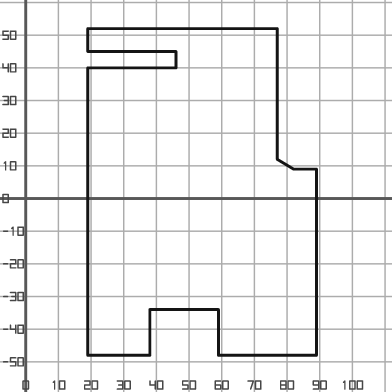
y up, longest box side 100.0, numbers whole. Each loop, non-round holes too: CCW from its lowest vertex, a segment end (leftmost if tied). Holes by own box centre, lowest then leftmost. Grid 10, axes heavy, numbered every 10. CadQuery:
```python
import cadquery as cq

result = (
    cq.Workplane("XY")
    .moveTo(19.0, -48.0)
    .lineTo(38.0, -48.0)
    .lineTo(38.0, -34.0)
    .lineTo(59.0, -34.0)
    .lineTo(59.0, -48.0)
    .lineTo(89.0, -48.0)
    .lineTo(89.0, 9.0)
    .lineTo(82.0, 9.0)
    .lineTo(77.0, 12.0)
    .lineTo(77.0, 52.0)
    .lineTo(19.0, 52.0)
    .lineTo(19.0, 45.0)
    .lineTo(46.0, 45.0)
    .lineTo(46.0, 40.0)
    .lineTo(19.0, 40.0)
    .close()
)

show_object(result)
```